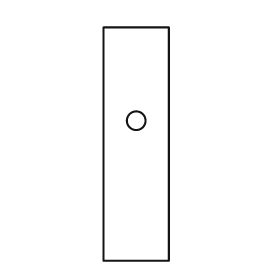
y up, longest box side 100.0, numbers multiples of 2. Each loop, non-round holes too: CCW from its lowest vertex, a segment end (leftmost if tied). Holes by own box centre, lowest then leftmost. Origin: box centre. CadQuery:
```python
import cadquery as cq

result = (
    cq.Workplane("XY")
    .moveTo(-14.0, -50.0)
    .lineTo(14.0, -50.0)
    .lineTo(14.0, 50.0)
    .lineTo(-14.0, 50.0)
    .close()
    .moveTo(0.0, 10.0)
    .circle(4.0)
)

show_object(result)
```